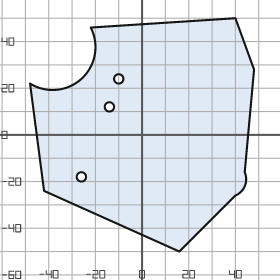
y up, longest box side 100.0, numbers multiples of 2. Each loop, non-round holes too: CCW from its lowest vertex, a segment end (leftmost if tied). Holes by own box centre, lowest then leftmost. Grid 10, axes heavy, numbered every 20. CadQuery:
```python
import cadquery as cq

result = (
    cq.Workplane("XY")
    .moveTo(16.0, -50.0)
    .lineTo(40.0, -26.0)
    .threePointArc((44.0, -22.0), (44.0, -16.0))
    .lineTo(48.0, 28.0)
    .lineTo(40.0, 50.0)
    .lineTo(-22.0, 46.0)
    .threePointArc((-26.0, 24.0), (-48.0, 22.0))
    .lineTo(-42.0, -24.0)
    .close()
    .moveTo(-26.0, -18.0)
    .circle(2.0)
    .moveTo(-14.0, 12.0)
    .circle(2.0)
    .moveTo(-10.0, 24.0)
    .circle(2.0)
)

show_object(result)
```